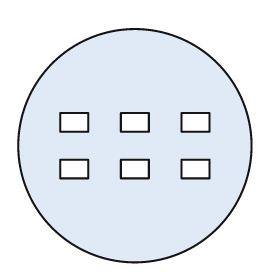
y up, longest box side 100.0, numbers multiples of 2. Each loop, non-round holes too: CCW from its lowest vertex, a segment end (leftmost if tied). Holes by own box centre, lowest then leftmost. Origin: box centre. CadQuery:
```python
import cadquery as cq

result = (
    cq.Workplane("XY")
    .moveTo(0.0, 0.0)
    .circle(50.0)
    .moveTo(-32.0, -14.0)
    .lineTo(-20.0, -14.0)
    .lineTo(-20.0, -6.0)
    .lineTo(-32.0, -6.0)
    .close()
    .moveTo(-6.0, -14.0)
    .lineTo(6.0, -14.0)
    .lineTo(6.0, -6.0)
    .lineTo(-6.0, -6.0)
    .close()
    .moveTo(20.0, -14.0)
    .lineTo(32.0, -14.0)
    .lineTo(32.0, -6.0)
    .lineTo(20.0, -6.0)
    .close()
    .moveTo(-32.0, 6.0)
    .lineTo(-20.0, 6.0)
    .lineTo(-20.0, 14.0)
    .lineTo(-32.0, 14.0)
    .close()
    .moveTo(-6.0, 6.0)
    .lineTo(6.0, 6.0)
    .lineTo(6.0, 14.0)
    .lineTo(-6.0, 14.0)
    .close()
    .moveTo(20.0, 6.0)
    .lineTo(32.0, 6.0)
    .lineTo(32.0, 14.0)
    .lineTo(20.0, 14.0)
    .close()
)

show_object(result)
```